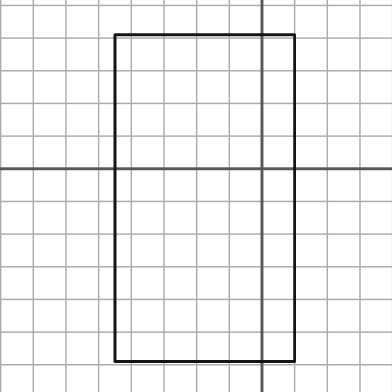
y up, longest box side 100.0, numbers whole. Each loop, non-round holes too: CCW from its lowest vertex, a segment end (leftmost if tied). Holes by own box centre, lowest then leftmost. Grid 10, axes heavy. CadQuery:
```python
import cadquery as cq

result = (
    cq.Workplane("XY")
    .moveTo(-45.0, -59.0)
    .lineTo(10.0, -59.0)
    .lineTo(10.0, 41.0)
    .lineTo(-45.0, 41.0)
    .close()
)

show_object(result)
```